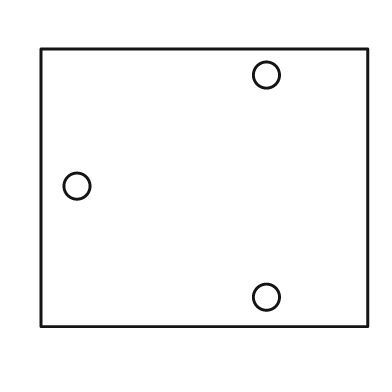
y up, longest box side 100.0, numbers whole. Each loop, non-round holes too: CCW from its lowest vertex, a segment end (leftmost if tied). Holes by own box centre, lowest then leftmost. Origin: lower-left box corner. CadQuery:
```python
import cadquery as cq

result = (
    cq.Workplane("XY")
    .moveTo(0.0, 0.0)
    .lineTo(100.0, 0.0)
    .lineTo(100.0, 85.0)
    .lineTo(0.0, 85.0)
    .close()
    .moveTo(69.0, 9.0)
    .circle(4.0)
    .moveTo(11.0, 43.0)
    .circle(4.0)
    .moveTo(69.0, 77.0)
    .circle(4.0)
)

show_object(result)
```